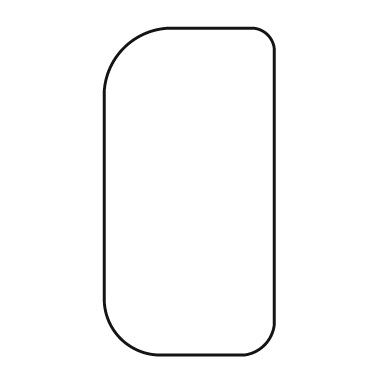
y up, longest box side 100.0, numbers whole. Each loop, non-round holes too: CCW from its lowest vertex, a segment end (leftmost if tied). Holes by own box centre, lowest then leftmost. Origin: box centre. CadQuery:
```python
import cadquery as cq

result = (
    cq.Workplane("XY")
    .moveTo(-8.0, -50.0)
    .lineTo(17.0, -50.0)
    .threePointArc((23.0, -47.0), (26.0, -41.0))
    .lineTo(26.0, 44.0)
    .threePointArc((24.0, 48.0), (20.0, 50.0))
    .lineTo(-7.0, 50.0)
    .threePointArc((-20.0, 44.0), (-26.0, 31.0))
    .lineTo(-26.0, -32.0)
    .threePointArc((-21.0, -45.0), (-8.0, -50.0))
    .close()
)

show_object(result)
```